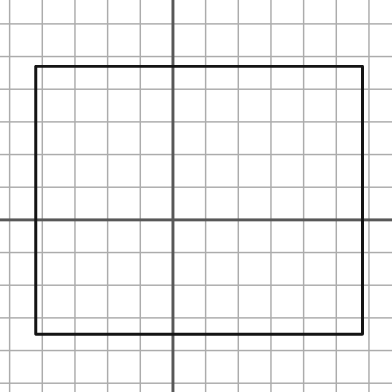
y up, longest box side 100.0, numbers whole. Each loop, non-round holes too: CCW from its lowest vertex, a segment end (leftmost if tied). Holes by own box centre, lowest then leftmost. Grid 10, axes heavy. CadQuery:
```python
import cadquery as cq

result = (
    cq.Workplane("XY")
    .moveTo(-42.0, -35.0)
    .lineTo(58.0, -35.0)
    .lineTo(58.0, 47.0)
    .lineTo(-42.0, 47.0)
    .close()
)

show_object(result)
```